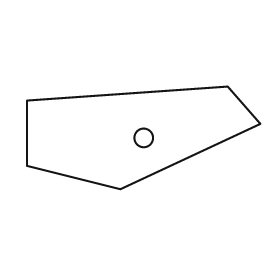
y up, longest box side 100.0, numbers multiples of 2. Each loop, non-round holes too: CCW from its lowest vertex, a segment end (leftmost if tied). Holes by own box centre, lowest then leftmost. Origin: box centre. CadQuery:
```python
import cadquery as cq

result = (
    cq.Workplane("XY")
    .moveTo(-10.0, -22.0)
    .lineTo(50.0, 6.0)
    .lineTo(36.0, 22.0)
    .lineTo(-50.0, 16.0)
    .lineTo(-50.0, -12.0)
    .close()
    .moveTo(0.0, 0.0)
    .circle(4.0)
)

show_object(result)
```